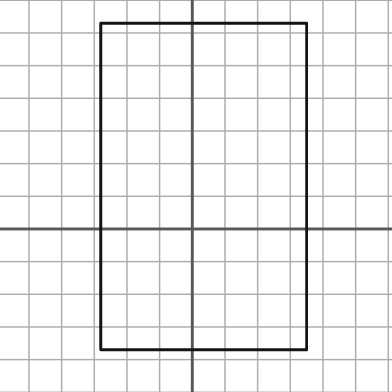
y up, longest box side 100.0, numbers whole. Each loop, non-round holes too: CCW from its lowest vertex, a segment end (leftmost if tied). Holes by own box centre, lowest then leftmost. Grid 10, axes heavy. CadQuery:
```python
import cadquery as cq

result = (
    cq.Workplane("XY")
    .moveTo(-28.0, -37.0)
    .lineTo(35.0, -37.0)
    .lineTo(35.0, 63.0)
    .lineTo(-28.0, 63.0)
    .close()
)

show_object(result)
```